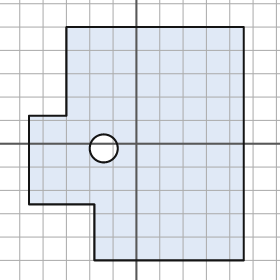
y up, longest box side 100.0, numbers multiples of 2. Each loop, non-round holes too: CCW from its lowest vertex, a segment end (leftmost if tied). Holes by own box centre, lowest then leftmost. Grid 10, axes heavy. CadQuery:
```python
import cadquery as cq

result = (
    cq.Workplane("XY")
    .moveTo(-18.0, -50.0)
    .lineTo(46.0, -50.0)
    .lineTo(46.0, 50.0)
    .lineTo(-30.0, 50.0)
    .lineTo(-30.0, 12.0)
    .lineTo(-46.0, 12.0)
    .lineTo(-46.0, -26.0)
    .lineTo(-18.0, -26.0)
    .close()
    .moveTo(-14.0, -2.0)
    .circle(6.0)
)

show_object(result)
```